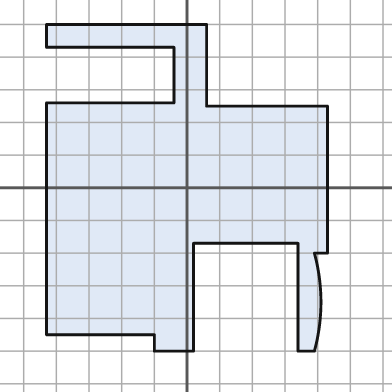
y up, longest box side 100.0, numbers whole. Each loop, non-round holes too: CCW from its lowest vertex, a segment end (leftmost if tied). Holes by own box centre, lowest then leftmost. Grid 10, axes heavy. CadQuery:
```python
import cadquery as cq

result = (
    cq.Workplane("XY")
    .moveTo(-10.0, -50.0)
    .lineTo(2.0, -50.0)
    .lineTo(2.0, -17.0)
    .lineTo(34.0, -17.0)
    .lineTo(34.0, -50.0)
    .lineTo(39.0, -50.0)
    .threePointArc((41.0, -35.0), (39.0, -20.0))
    .lineTo(43.0, -20.0)
    .lineTo(43.0, 25.0)
    .lineTo(6.0, 25.0)
    .lineTo(6.0, 50.0)
    .lineTo(-43.0, 50.0)
    .lineTo(-43.0, 43.0)
    .lineTo(-4.0, 43.0)
    .lineTo(-4.0, 26.0)
    .lineTo(-43.0, 26.0)
    .lineTo(-43.0, -45.0)
    .lineTo(-10.0, -45.0)
    .close()
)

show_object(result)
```